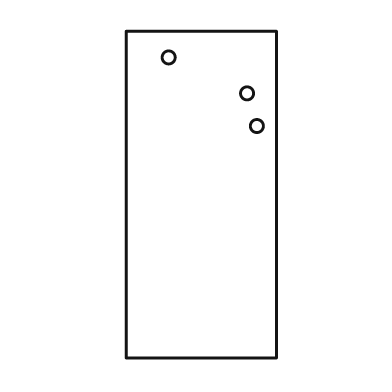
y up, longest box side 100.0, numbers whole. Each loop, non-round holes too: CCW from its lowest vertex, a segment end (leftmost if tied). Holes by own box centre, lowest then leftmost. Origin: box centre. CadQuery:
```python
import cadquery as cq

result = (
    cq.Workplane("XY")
    .moveTo(-23.0, -50.0)
    .lineTo(23.0, -50.0)
    .lineTo(23.0, 50.0)
    .lineTo(-23.0, 50.0)
    .close()
    .moveTo(17.0, 21.0)
    .circle(2.0)
    .moveTo(14.0, 31.0)
    .circle(2.0)
    .moveTo(-10.0, 42.0)
    .circle(2.0)
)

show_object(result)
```